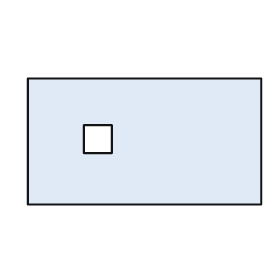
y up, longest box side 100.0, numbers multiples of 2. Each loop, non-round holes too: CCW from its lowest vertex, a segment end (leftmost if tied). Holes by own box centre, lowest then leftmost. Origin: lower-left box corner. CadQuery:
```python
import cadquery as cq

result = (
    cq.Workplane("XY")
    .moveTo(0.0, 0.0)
    .lineTo(100.0, 0.0)
    .lineTo(100.0, 54.0)
    .lineTo(0.0, 54.0)
    .close()
    .moveTo(24.0, 22.0)
    .lineTo(36.0, 22.0)
    .lineTo(36.0, 34.0)
    .lineTo(24.0, 34.0)
    .close()
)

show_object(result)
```